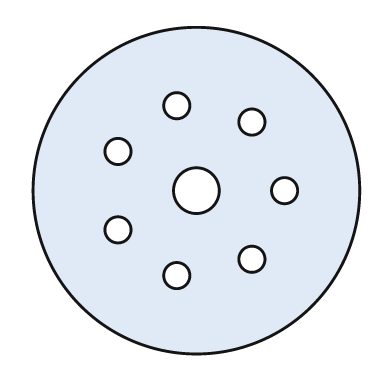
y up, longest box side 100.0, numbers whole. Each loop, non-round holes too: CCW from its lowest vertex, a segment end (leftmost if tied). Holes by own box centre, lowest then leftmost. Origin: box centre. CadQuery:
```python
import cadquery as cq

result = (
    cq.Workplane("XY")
    .moveTo(0.0, 0.0)
    .circle(50.0)
    .moveTo(-6.0, -26.0)
    .circle(4.0)
    .moveTo(17.0, -21.0)
    .circle(4.0)
    .moveTo(-24.0, -12.0)
    .circle(4.0)
    .moveTo(0.0, 0.0)
    .circle(7.0)
    .moveTo(27.0, 0.0)
    .circle(4.0)
    .moveTo(-24.0, 12.0)
    .circle(4.0)
    .moveTo(17.0, 21.0)
    .circle(4.0)
    .moveTo(-6.0, 26.0)
    .circle(4.0)
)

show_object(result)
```